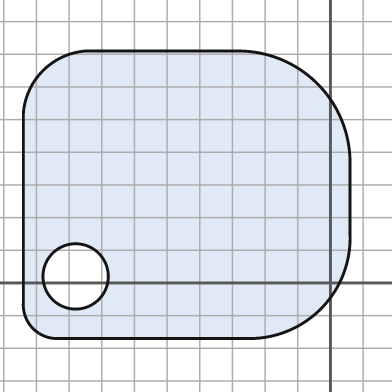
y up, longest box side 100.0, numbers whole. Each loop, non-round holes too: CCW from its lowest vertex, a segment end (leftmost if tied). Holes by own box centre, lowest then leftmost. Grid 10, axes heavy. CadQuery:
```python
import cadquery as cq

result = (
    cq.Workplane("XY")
    .moveTo(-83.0, -17.0)
    .lineTo(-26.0, -17.0)
    .threePointArc((-3.0, -8.0), (6.0, 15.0))
    .lineTo(6.0, 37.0)
    .threePointArc((-4.0, 61.0), (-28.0, 71.0))
    .lineTo(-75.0, 71.0)
    .threePointArc((-88.0, 65.0), (-94.0, 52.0))
    .lineTo(-94.0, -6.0)
    .threePointArc((-91.0, -14.0), (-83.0, -17.0))
    .close()
    .moveTo(-78.0, 2.0)
    .circle(10.0)
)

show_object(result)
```